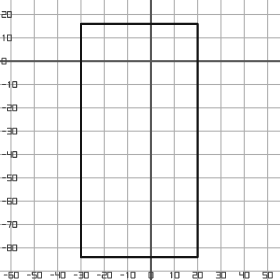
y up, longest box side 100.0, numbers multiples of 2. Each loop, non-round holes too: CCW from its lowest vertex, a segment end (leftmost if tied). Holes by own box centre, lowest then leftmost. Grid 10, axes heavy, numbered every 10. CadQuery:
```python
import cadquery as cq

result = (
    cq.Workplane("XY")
    .moveTo(-30.0, -84.0)
    .lineTo(20.0, -84.0)
    .lineTo(20.0, 16.0)
    .lineTo(-30.0, 16.0)
    .close()
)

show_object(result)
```